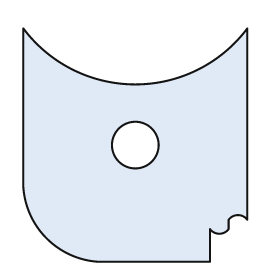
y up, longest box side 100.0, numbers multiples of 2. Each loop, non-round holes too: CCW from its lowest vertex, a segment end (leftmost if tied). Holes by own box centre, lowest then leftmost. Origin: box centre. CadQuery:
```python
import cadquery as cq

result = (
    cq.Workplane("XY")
    .moveTo(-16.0, -50.0)
    .lineTo(32.0, -50.0)
    .lineTo(32.0, -36.0)
    .threePointArc((36.0, -38.0), (40.0, -36.0))
    .lineTo(40.0, -32.0)
    .threePointArc((44.0, -30.0), (48.0, -32.0))
    .lineTo(48.0, 50.0)
    .threePointArc((0.0, 26.0), (-48.0, 50.0))
    .lineTo(-48.0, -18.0)
    .threePointArc((-38.0, -40.0), (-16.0, -50.0))
    .close()
    .moveTo(0.0, 0.0)
    .circle(10.0)
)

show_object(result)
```